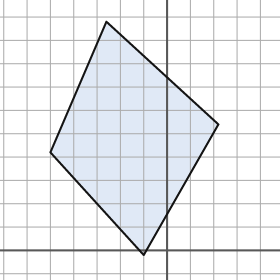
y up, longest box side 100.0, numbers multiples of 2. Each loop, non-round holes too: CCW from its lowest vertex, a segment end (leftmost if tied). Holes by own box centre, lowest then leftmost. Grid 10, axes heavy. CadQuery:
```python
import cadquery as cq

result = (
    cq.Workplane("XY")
    .moveTo(-10.0, -2.0)
    .lineTo(22.0, 54.0)
    .lineTo(-26.0, 98.0)
    .lineTo(-50.0, 42.0)
    .close()
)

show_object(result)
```